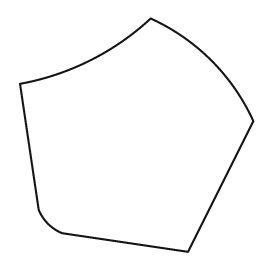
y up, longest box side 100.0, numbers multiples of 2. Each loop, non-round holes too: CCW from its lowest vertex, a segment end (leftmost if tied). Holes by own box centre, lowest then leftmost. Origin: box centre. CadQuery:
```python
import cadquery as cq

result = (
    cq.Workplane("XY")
    .moveTo(22.0, -50.0)
    .lineTo(50.0, 6.0)
    .threePointArc((32.0, 32.0), (6.0, 50.0))
    .threePointArc((-20.0, 32.0), (-50.0, 22.0))
    .lineTo(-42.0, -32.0)
    .threePointArc((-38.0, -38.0), (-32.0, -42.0))
    .close()
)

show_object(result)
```